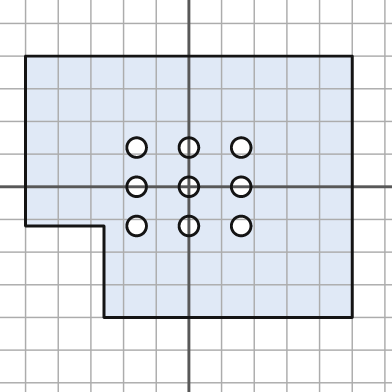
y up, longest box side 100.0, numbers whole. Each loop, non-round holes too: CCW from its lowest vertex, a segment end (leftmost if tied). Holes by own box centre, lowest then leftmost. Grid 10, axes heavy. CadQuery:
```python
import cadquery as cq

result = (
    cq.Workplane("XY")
    .moveTo(-26.0, -40.0)
    .lineTo(50.0, -40.0)
    .lineTo(50.0, 40.0)
    .lineTo(-50.0, 40.0)
    .lineTo(-50.0, -12.0)
    .lineTo(-26.0, -12.0)
    .close()
    .moveTo(-16.0, -12.0)
    .circle(3.0)
    .moveTo(0.0, -12.0)
    .circle(3.0)
    .moveTo(16.0, -12.0)
    .circle(3.0)
    .moveTo(-16.0, 0.0)
    .circle(3.0)
    .moveTo(0.0, 0.0)
    .circle(3.0)
    .moveTo(16.0, 0.0)
    .circle(3.0)
    .moveTo(-16.0, 12.0)
    .circle(3.0)
    .moveTo(0.0, 12.0)
    .circle(3.0)
    .moveTo(16.0, 12.0)
    .circle(3.0)
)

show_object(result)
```